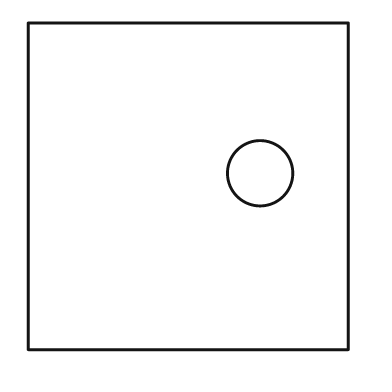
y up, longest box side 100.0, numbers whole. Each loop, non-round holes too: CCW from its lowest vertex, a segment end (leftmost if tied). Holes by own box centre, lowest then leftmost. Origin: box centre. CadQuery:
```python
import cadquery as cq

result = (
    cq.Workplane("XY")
    .moveTo(-49.0, -50.0)
    .lineTo(49.0, -50.0)
    .lineTo(49.0, 50.0)
    .lineTo(-49.0, 50.0)
    .close()
    .moveTo(22.0, 4.0)
    .circle(10.0)
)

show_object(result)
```